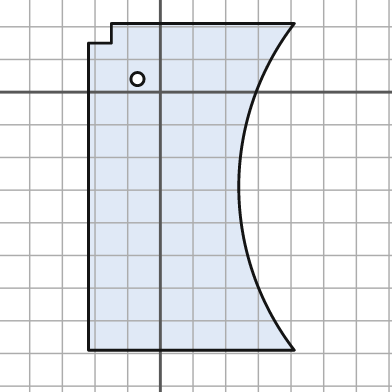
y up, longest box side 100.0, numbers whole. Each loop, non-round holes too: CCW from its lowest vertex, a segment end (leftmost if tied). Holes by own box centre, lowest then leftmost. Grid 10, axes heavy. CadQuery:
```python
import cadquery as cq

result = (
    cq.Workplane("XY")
    .moveTo(-22.0, -79.0)
    .lineTo(41.0, -79.0)
    .threePointArc((24.0, -29.0), (41.0, 21.0))
    .lineTo(-15.0, 21.0)
    .lineTo(-15.0, 15.0)
    .lineTo(-22.0, 15.0)
    .close()
    .moveTo(-7.0, 4.0)
    .circle(2.0)
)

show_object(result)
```